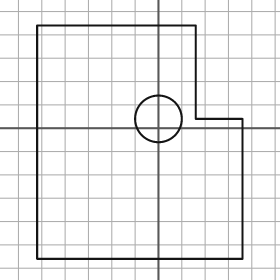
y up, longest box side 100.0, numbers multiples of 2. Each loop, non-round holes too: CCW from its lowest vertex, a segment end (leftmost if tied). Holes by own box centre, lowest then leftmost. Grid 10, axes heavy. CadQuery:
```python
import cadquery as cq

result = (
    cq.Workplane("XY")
    .moveTo(-52.0, -56.0)
    .lineTo(36.0, -56.0)
    .lineTo(36.0, 4.0)
    .lineTo(16.0, 4.0)
    .lineTo(16.0, 44.0)
    .lineTo(-52.0, 44.0)
    .close()
    .moveTo(0.0, 4.0)
    .circle(10.0)
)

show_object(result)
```